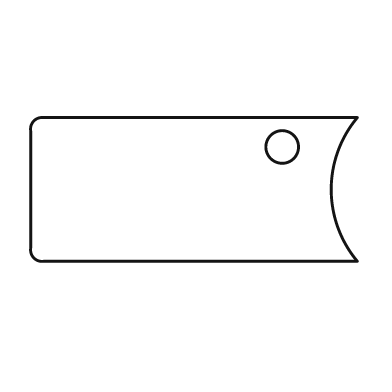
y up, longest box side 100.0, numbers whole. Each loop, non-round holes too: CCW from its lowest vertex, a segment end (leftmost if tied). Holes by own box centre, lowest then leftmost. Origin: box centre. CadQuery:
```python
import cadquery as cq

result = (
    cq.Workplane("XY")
    .moveTo(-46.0, -22.0)
    .lineTo(50.0, -22.0)
    .threePointArc((42.0, 0.0), (50.0, 22.0))
    .lineTo(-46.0, 22.0)
    .threePointArc((-49.0, 21.0), (-50.0, 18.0))
    .lineTo(-50.0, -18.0)
    .threePointArc((-49.0, -21.0), (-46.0, -22.0))
    .close()
    .moveTo(27.0, 13.0)
    .circle(5.0)
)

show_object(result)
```